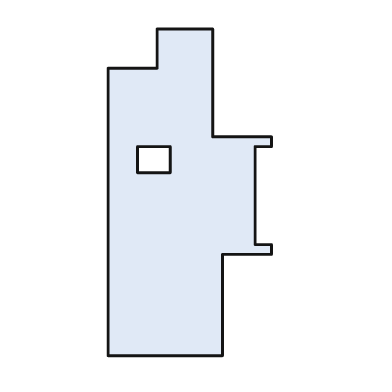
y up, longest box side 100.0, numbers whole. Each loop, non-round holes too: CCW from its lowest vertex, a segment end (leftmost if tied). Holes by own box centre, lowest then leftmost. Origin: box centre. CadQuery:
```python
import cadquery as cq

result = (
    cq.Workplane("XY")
    .moveTo(-25.0, -50.0)
    .lineTo(10.0, -50.0)
    .lineTo(10.0, -19.0)
    .lineTo(25.0, -19.0)
    .lineTo(25.0, -16.0)
    .lineTo(20.0, -16.0)
    .lineTo(20.0, 14.0)
    .lineTo(25.0, 14.0)
    .lineTo(25.0, 17.0)
    .lineTo(7.0, 17.0)
    .lineTo(7.0, 50.0)
    .lineTo(-10.0, 50.0)
    .lineTo(-10.0, 38.0)
    .lineTo(-25.0, 38.0)
    .close()
    .moveTo(-16.0, 6.0)
    .lineTo(-6.0, 6.0)
    .lineTo(-6.0, 14.0)
    .lineTo(-16.0, 14.0)
    .close()
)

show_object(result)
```